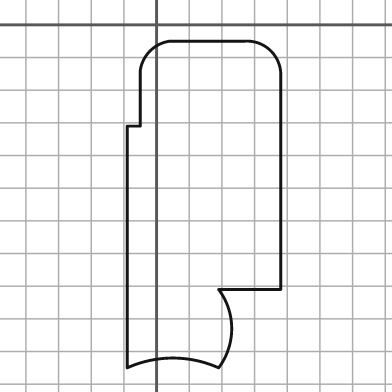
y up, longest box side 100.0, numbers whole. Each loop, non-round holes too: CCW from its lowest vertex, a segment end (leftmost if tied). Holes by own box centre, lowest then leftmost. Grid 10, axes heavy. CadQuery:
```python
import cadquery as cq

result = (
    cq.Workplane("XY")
    .moveTo(-9.0, -105.0)
    .threePointArc((5.0, -102.0), (19.0, -105.0))
    .threePointArc((23.0, -93.0), (19.0, -81.0))
    .lineTo(38.0, -81.0)
    .lineTo(38.0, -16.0)
    .threePointArc((35.0, -8.0), (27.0, -5.0))
    .lineTo(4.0, -5.0)
    .threePointArc((-2.0, -8.0), (-5.0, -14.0))
    .lineTo(-5.0, -31.0)
    .lineTo(-9.0, -31.0)
    .close()
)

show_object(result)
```